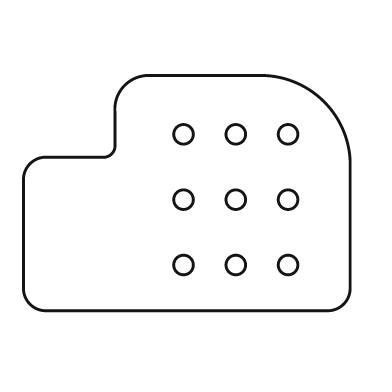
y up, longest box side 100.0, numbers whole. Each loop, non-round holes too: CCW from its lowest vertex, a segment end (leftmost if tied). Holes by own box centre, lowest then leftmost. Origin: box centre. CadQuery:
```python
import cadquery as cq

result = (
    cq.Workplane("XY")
    .moveTo(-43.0, -36.0)
    .lineTo(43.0, -36.0)
    .threePointArc((48.0, -34.0), (50.0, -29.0))
    .lineTo(50.0, 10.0)
    .threePointArc((42.0, 28.0), (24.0, 36.0))
    .lineTo(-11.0, 36.0)
    .threePointArc((-19.0, 33.0), (-22.0, 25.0))
    .lineTo(-22.0, 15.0)
    .threePointArc((-23.0, 12.0), (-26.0, 11.0))
    .lineTo(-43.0, 11.0)
    .threePointArc((-48.0, 9.0), (-50.0, 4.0))
    .lineTo(-50.0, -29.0)
    .threePointArc((-48.0, -34.0), (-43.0, -36.0))
    .close()
    .moveTo(-1.0, -22.0)
    .circle(3.0)
    .moveTo(15.0, -22.0)
    .circle(3.0)
    .moveTo(31.0, -22.0)
    .circle(3.0)
    .moveTo(-1.0, -2.0)
    .circle(3.0)
    .moveTo(15.0, -2.0)
    .circle(3.0)
    .moveTo(31.0, -2.0)
    .circle(3.0)
    .moveTo(-1.0, 18.0)
    .circle(3.0)
    .moveTo(15.0, 18.0)
    .circle(3.0)
    .moveTo(31.0, 18.0)
    .circle(3.0)
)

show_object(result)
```